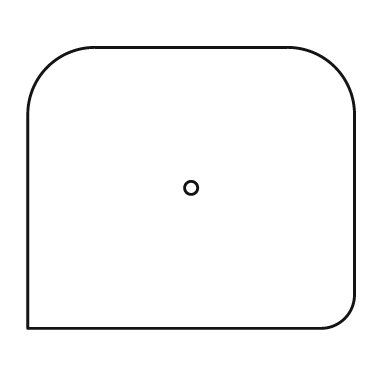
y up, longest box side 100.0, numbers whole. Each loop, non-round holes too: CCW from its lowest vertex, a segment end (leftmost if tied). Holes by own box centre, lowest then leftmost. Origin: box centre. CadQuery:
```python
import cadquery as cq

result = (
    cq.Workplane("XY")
    .moveTo(-50.0, -43.0)
    .lineTo(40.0, -43.0)
    .threePointArc((47.0, -40.0), (50.0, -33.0))
    .lineTo(50.0, 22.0)
    .threePointArc((44.0, 37.0), (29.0, 43.0))
    .lineTo(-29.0, 43.0)
    .threePointArc((-44.0, 37.0), (-50.0, 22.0))
    .close()
    .moveTo(0.0, 0.0)
    .circle(2.0)
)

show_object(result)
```